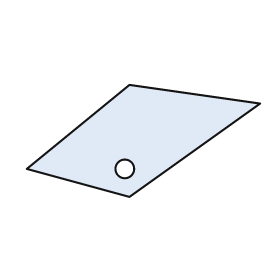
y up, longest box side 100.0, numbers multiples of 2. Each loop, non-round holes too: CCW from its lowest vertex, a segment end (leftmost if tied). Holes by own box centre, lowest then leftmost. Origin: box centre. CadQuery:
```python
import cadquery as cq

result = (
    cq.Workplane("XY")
    .moveTo(-6.0, -24.0)
    .lineTo(50.0, 16.0)
    .lineTo(-6.0, 24.0)
    .lineTo(-50.0, -12.0)
    .close()
    .moveTo(-8.0, -12.0)
    .circle(4.0)
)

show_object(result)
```